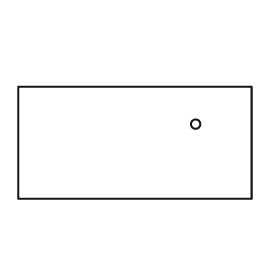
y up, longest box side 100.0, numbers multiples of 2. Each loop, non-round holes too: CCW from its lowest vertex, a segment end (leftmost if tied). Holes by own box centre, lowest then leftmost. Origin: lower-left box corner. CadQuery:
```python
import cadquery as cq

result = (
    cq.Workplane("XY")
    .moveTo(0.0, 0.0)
    .lineTo(100.0, 0.0)
    .lineTo(100.0, 48.0)
    .lineTo(0.0, 48.0)
    .close()
    .moveTo(76.0, 32.0)
    .circle(2.0)
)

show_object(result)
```